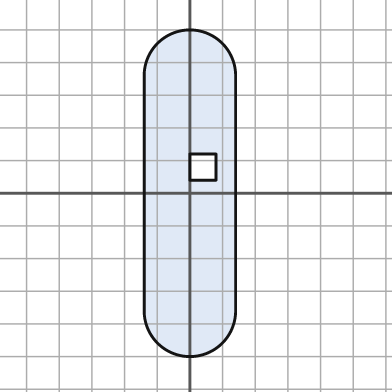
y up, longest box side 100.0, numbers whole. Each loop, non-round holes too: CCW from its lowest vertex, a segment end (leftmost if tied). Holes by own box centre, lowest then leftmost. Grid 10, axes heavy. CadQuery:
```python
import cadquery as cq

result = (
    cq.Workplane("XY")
    .moveTo(-14.0, -36.0)
    .threePointArc((0.0, -50.0), (14.0, -36.0))
    .lineTo(14.0, 36.0)
    .threePointArc((0.0, 50.0), (-14.0, 36.0))
    .close()
    .moveTo(0.0, 4.0)
    .lineTo(8.0, 4.0)
    .lineTo(8.0, 12.0)
    .lineTo(0.0, 12.0)
    .close()
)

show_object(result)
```